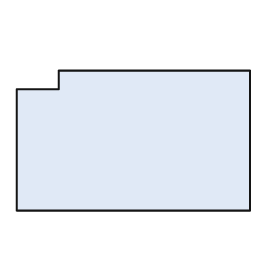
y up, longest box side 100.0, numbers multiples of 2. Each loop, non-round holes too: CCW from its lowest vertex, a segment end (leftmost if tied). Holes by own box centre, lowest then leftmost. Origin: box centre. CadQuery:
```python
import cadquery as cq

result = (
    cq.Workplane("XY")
    .moveTo(-50.0, -30.0)
    .lineTo(50.0, -30.0)
    .lineTo(50.0, 30.0)
    .lineTo(-32.0, 30.0)
    .lineTo(-32.0, 22.0)
    .lineTo(-50.0, 22.0)
    .close()
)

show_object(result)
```